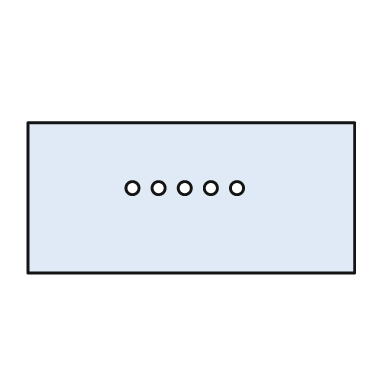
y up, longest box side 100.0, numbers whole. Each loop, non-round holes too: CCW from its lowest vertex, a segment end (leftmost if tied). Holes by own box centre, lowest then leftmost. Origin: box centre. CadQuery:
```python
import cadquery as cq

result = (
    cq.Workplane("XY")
    .moveTo(-50.0, -23.0)
    .lineTo(50.0, -23.0)
    .lineTo(50.0, 23.0)
    .lineTo(-50.0, 23.0)
    .close()
    .moveTo(-18.0, 3.0)
    .circle(2.0)
    .moveTo(-10.0, 3.0)
    .circle(2.0)
    .moveTo(-2.0, 3.0)
    .circle(2.0)
    .moveTo(6.0, 3.0)
    .circle(2.0)
    .moveTo(14.0, 3.0)
    .circle(2.0)
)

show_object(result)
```